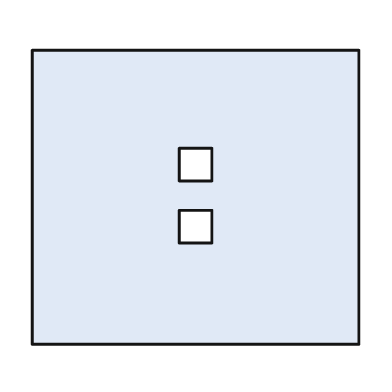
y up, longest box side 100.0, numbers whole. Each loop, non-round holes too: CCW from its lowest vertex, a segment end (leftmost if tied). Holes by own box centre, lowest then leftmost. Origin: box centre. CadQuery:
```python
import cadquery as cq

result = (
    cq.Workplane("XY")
    .moveTo(-50.0, -45.0)
    .lineTo(50.0, -45.0)
    .lineTo(50.0, 45.0)
    .lineTo(-50.0, 45.0)
    .close()
    .moveTo(-5.0, -14.0)
    .lineTo(5.0, -14.0)
    .lineTo(5.0, -4.0)
    .lineTo(-5.0, -4.0)
    .close()
    .moveTo(-5.0, 5.0)
    .lineTo(5.0, 5.0)
    .lineTo(5.0, 15.0)
    .lineTo(-5.0, 15.0)
    .close()
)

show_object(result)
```